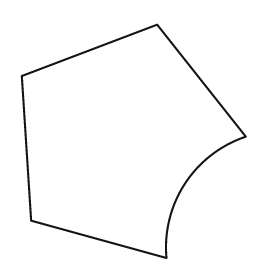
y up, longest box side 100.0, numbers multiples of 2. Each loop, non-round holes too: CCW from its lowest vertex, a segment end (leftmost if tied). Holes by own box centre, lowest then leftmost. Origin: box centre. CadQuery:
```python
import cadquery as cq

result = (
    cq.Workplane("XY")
    .moveTo(14.0, -50.0)
    .threePointArc((22.0, -18.0), (48.0, 2.0))
    .lineTo(10.0, 50.0)
    .lineTo(-48.0, 28.0)
    .lineTo(-44.0, -34.0)
    .close()
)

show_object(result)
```